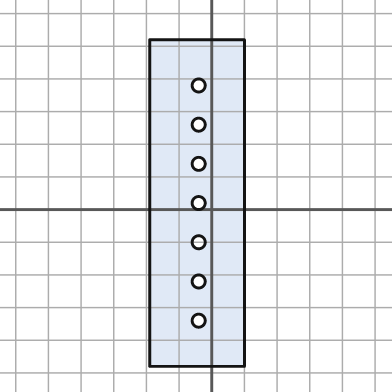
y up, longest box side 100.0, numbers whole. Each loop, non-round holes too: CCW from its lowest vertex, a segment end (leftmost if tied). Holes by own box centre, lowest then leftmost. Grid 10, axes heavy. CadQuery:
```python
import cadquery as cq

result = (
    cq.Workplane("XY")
    .moveTo(-19.0, -48.0)
    .lineTo(10.0, -48.0)
    .lineTo(10.0, 52.0)
    .lineTo(-19.0, 52.0)
    .close()
    .moveTo(-4.0, -34.0)
    .circle(2.0)
    .moveTo(-4.0, -22.0)
    .circle(2.0)
    .moveTo(-4.0, -10.0)
    .circle(2.0)
    .moveTo(-4.0, 2.0)
    .circle(2.0)
    .moveTo(-4.0, 14.0)
    .circle(2.0)
    .moveTo(-4.0, 26.0)
    .circle(2.0)
    .moveTo(-4.0, 38.0)
    .circle(2.0)
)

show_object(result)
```